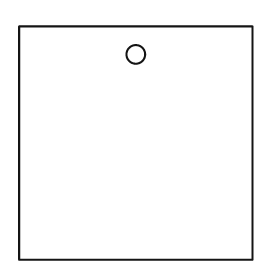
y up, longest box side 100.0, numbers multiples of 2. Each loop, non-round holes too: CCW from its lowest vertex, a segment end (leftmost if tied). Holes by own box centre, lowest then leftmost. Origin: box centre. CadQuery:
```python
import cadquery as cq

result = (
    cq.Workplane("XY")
    .moveTo(-50.0, -50.0)
    .lineTo(50.0, -50.0)
    .lineTo(50.0, 50.0)
    .lineTo(-50.0, 50.0)
    .close()
    .moveTo(0.0, 38.0)
    .circle(4.0)
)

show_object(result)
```